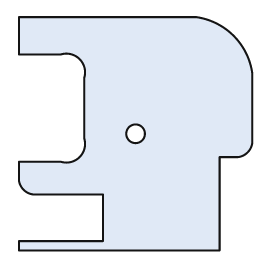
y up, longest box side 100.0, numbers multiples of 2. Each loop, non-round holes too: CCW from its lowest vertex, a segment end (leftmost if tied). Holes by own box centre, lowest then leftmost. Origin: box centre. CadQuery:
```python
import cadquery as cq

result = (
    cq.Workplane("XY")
    .moveTo(-50.0, -50.0)
    .lineTo(36.0, -50.0)
    .lineTo(36.0, -10.0)
    .lineTo(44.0, -10.0)
    .threePointArc((48.0, -8.0), (50.0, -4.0))
    .lineTo(50.0, 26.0)
    .threePointArc((42.0, 42.0), (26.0, 50.0))
    .lineTo(-50.0, 50.0)
    .lineTo(-50.0, 34.0)
    .lineTo(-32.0, 34.0)
    .threePointArc((-24.0, 32.0), (-22.0, 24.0))
    .lineTo(-22.0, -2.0)
    .threePointArc((-24.0, -10.0), (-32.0, -12.0))
    .lineTo(-50.0, -12.0)
    .lineTo(-50.0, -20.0)
    .threePointArc((-48.0, -24.0), (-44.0, -26.0))
    .lineTo(-14.0, -26.0)
    .lineTo(-14.0, -46.0)
    .lineTo(-50.0, -46.0)
    .close()
    .moveTo(0.0, 0.0)
    .circle(4.0)
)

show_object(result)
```